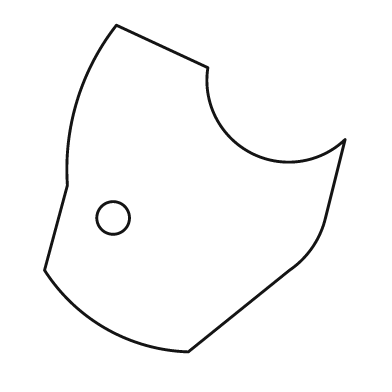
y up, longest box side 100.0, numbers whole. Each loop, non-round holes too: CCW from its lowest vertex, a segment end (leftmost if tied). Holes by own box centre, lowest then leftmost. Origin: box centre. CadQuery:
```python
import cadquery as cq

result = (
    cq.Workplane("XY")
    .moveTo(-2.0, -50.0)
    .lineTo(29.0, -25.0)
    .threePointArc((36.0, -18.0), (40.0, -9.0))
    .lineTo(46.0, 15.0)
    .threePointArc((17.0, 11.0), (4.0, 37.0))
    .lineTo(-24.0, 50.0)
    .threePointArc((-36.0, 27.0), (-39.0, 1.0))
    .lineTo(-46.0, -25.0)
    .threePointArc((-27.0, -43.0), (-2.0, -50.0))
    .close()
    .moveTo(-25.0, -9.0)
    .circle(5.0)
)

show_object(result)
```